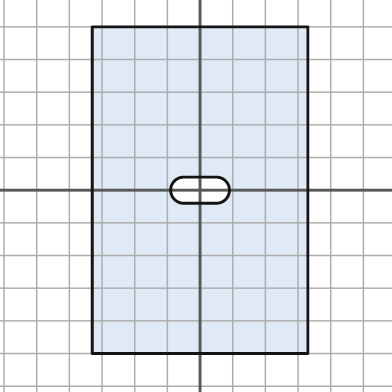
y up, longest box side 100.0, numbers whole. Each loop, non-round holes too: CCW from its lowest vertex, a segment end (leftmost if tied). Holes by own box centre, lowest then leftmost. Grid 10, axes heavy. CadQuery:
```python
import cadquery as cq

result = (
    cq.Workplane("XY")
    .moveTo(-33.0, -50.0)
    .lineTo(33.0, -50.0)
    .lineTo(33.0, 50.0)
    .lineTo(-33.0, 50.0)
    .close()
    .moveTo(-5.0, -4.0)
    .lineTo(5.0, -4.0)
    .threePointArc((9.0, 0.0), (5.0, 4.0))
    .lineTo(-5.0, 4.0)
    .threePointArc((-9.0, 0.0), (-5.0, -4.0))
    .close()
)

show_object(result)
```